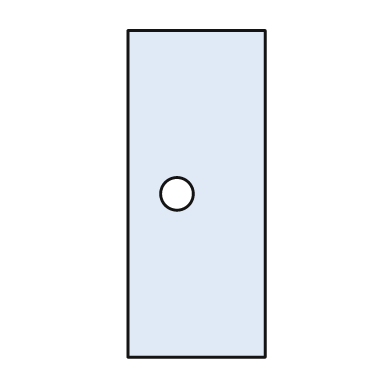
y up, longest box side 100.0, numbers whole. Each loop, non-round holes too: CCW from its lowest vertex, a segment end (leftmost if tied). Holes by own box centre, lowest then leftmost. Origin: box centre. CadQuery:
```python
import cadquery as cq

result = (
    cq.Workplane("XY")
    .moveTo(-21.0, -50.0)
    .lineTo(21.0, -50.0)
    .lineTo(21.0, 50.0)
    .lineTo(-21.0, 50.0)
    .close()
    .moveTo(-6.0, 0.0)
    .circle(5.0)
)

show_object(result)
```